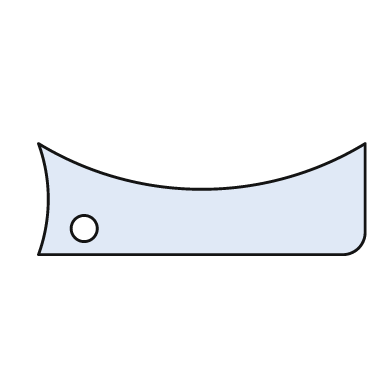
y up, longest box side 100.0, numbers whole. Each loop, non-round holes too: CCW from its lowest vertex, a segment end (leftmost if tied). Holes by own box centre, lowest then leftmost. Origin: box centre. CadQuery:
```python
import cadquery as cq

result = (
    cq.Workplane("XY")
    .moveTo(-50.0, -17.0)
    .lineTo(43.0, -17.0)
    .threePointArc((48.0, -15.0), (50.0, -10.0))
    .lineTo(50.0, 17.0)
    .threePointArc((0.0, 3.0), (-50.0, 17.0))
    .threePointArc((-47.0, 0.0), (-50.0, -17.0))
    .close()
    .moveTo(-36.0, -9.0)
    .circle(4.0)
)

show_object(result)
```